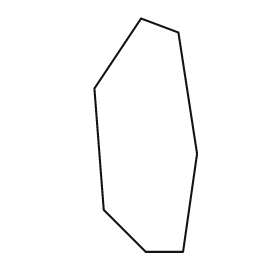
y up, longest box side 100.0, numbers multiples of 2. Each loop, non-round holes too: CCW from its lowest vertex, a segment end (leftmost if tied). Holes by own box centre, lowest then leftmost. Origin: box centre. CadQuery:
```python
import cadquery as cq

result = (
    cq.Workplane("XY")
    .moveTo(0.0, -50.0)
    .lineTo(16.0, -50.0)
    .lineTo(22.0, -8.0)
    .lineTo(14.0, 44.0)
    .lineTo(-2.0, 50.0)
    .lineTo(-22.0, 20.0)
    .lineTo(-18.0, -32.0)
    .close()
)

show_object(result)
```